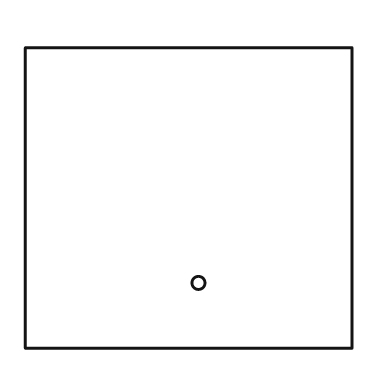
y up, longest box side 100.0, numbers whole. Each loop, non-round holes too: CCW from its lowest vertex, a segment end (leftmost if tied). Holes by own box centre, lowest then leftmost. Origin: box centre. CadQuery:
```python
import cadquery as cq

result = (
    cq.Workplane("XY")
    .moveTo(-50.0, -46.0)
    .lineTo(50.0, -46.0)
    .lineTo(50.0, 46.0)
    .lineTo(-50.0, 46.0)
    .close()
    .moveTo(3.0, -26.0)
    .circle(2.0)
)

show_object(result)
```